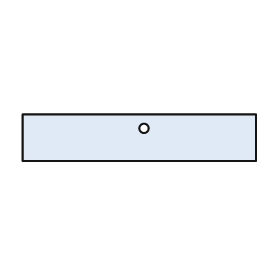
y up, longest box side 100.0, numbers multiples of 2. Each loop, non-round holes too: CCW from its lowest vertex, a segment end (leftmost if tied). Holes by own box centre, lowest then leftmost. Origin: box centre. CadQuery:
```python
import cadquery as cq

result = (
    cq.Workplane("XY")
    .moveTo(-50.0, -10.0)
    .lineTo(50.0, -10.0)
    .lineTo(50.0, 10.0)
    .lineTo(-50.0, 10.0)
    .close()
    .moveTo(2.0, 4.0)
    .circle(2.0)
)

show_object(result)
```